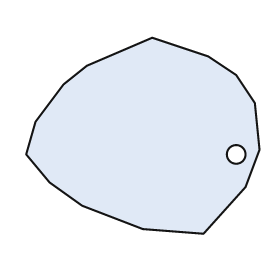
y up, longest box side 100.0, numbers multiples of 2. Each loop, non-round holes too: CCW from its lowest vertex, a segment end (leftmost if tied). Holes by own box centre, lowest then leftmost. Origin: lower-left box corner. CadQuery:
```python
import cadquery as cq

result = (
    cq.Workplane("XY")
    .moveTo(76.0, 0.0)
    .lineTo(94.0, 20.0)
    .lineTo(100.0, 36.0)
    .lineTo(98.0, 56.0)
    .lineTo(90.0, 68.0)
    .lineTo(78.0, 76.0)
    .lineTo(54.0, 84.0)
    .lineTo(26.0, 72.0)
    .lineTo(16.0, 64.0)
    .lineTo(4.0, 48.0)
    .lineTo(0.0, 34.0)
    .lineTo(10.0, 22.0)
    .lineTo(24.0, 12.0)
    .lineTo(50.0, 2.0)
    .close()
    .moveTo(90.0, 34.0)
    .circle(4.0)
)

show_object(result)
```